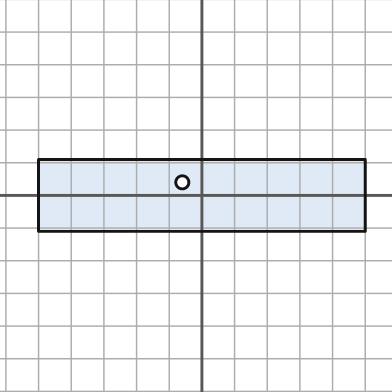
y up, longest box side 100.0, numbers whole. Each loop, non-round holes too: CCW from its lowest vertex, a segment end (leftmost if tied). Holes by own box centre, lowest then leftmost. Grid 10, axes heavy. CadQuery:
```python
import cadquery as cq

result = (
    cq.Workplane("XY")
    .moveTo(-50.0, -11.0)
    .lineTo(50.0, -11.0)
    .lineTo(50.0, 11.0)
    .lineTo(-50.0, 11.0)
    .close()
    .moveTo(-6.0, 4.0)
    .circle(2.0)
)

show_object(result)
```